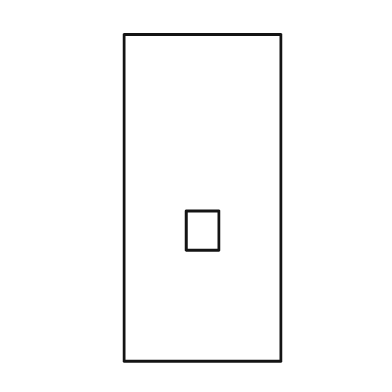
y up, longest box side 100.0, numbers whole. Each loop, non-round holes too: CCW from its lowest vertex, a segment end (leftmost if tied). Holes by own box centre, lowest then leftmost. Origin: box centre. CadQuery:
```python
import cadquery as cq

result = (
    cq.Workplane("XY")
    .moveTo(-24.0, -50.0)
    .lineTo(24.0, -50.0)
    .lineTo(24.0, 50.0)
    .lineTo(-24.0, 50.0)
    .close()
    .moveTo(-5.0, -16.0)
    .lineTo(5.0, -16.0)
    .lineTo(5.0, -4.0)
    .lineTo(-5.0, -4.0)
    .close()
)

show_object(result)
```